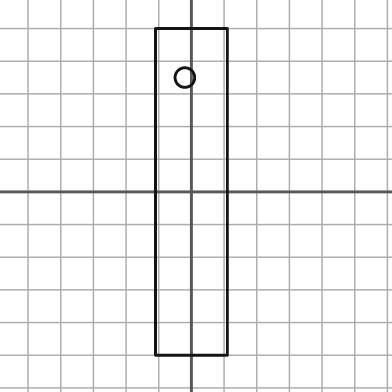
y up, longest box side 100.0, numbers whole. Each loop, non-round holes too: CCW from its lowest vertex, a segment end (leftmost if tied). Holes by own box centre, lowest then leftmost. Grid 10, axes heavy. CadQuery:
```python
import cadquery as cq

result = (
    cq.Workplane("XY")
    .moveTo(-11.0, -50.0)
    .lineTo(11.0, -50.0)
    .lineTo(11.0, 50.0)
    .lineTo(-11.0, 50.0)
    .close()
    .moveTo(-2.0, 35.0)
    .circle(3.0)
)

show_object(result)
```